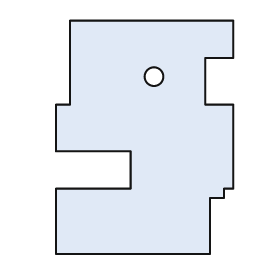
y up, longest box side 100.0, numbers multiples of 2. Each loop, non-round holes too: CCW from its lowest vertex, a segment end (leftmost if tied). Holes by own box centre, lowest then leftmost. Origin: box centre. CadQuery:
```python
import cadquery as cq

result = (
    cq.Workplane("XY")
    .moveTo(-38.0, -50.0)
    .lineTo(28.0, -50.0)
    .lineTo(28.0, -26.0)
    .lineTo(34.0, -26.0)
    .lineTo(34.0, -22.0)
    .lineTo(38.0, -22.0)
    .lineTo(38.0, 14.0)
    .lineTo(26.0, 14.0)
    .lineTo(26.0, 34.0)
    .lineTo(38.0, 34.0)
    .lineTo(38.0, 50.0)
    .lineTo(-32.0, 50.0)
    .lineTo(-32.0, 14.0)
    .lineTo(-38.0, 14.0)
    .lineTo(-38.0, -6.0)
    .lineTo(-6.0, -6.0)
    .lineTo(-6.0, -22.0)
    .lineTo(-38.0, -22.0)
    .close()
    .moveTo(4.0, 26.0)
    .circle(4.0)
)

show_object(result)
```